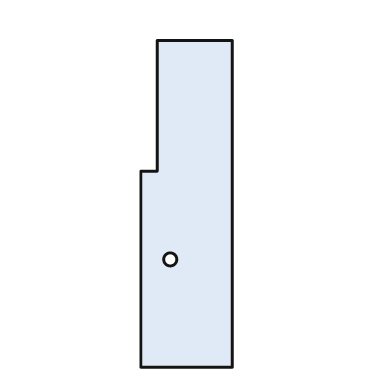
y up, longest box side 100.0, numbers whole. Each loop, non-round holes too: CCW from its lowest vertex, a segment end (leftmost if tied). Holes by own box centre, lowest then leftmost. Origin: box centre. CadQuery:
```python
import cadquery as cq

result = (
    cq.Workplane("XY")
    .moveTo(-14.0, -50.0)
    .lineTo(14.0, -50.0)
    .lineTo(14.0, 50.0)
    .lineTo(-9.0, 50.0)
    .lineTo(-9.0, 10.0)
    .lineTo(-14.0, 10.0)
    .close()
    .moveTo(-5.0, -17.0)
    .circle(2.0)
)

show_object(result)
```